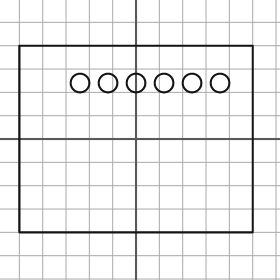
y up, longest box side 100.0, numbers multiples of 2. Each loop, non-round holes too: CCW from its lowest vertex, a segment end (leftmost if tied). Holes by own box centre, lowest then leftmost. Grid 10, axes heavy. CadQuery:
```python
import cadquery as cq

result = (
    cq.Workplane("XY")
    .moveTo(-50.0, -40.0)
    .lineTo(50.0, -40.0)
    .lineTo(50.0, 40.0)
    .lineTo(-50.0, 40.0)
    .close()
    .moveTo(-24.0, 24.0)
    .circle(4.0)
    .moveTo(-12.0, 24.0)
    .circle(4.0)
    .moveTo(0.0, 24.0)
    .circle(4.0)
    .moveTo(12.0, 24.0)
    .circle(4.0)
    .moveTo(24.0, 24.0)
    .circle(4.0)
    .moveTo(36.0, 24.0)
    .circle(4.0)
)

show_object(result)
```